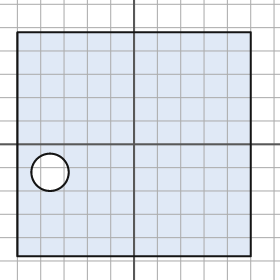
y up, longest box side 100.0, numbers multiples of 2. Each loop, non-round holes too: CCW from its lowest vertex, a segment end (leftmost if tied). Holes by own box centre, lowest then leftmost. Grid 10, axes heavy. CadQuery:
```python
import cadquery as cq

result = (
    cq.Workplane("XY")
    .moveTo(-50.0, -48.0)
    .lineTo(50.0, -48.0)
    .lineTo(50.0, 48.0)
    .lineTo(-50.0, 48.0)
    .close()
    .moveTo(-36.0, -12.0)
    .circle(8.0)
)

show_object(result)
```